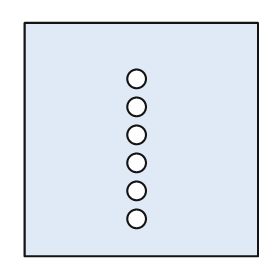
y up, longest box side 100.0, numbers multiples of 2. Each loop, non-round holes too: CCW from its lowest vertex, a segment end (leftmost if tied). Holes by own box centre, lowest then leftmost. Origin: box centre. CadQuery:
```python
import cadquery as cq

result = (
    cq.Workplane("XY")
    .moveTo(-50.0, -50.0)
    .lineTo(50.0, -50.0)
    .lineTo(50.0, 50.0)
    .lineTo(-50.0, 50.0)
    .close()
    .moveTo(-2.0, -34.0)
    .circle(4.0)
    .moveTo(-2.0, -22.0)
    .circle(4.0)
    .moveTo(-2.0, -10.0)
    .circle(4.0)
    .moveTo(-2.0, 2.0)
    .circle(4.0)
    .moveTo(-2.0, 14.0)
    .circle(4.0)
    .moveTo(-2.0, 26.0)
    .circle(4.0)
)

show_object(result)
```